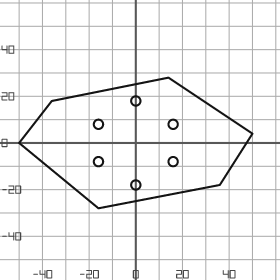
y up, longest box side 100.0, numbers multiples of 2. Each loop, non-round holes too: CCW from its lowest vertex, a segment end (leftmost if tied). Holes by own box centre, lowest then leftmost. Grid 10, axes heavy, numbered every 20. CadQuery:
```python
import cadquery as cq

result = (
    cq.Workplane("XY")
    .moveTo(-16.0, -28.0)
    .lineTo(36.0, -18.0)
    .lineTo(50.0, 4.0)
    .lineTo(14.0, 28.0)
    .lineTo(-36.0, 18.0)
    .lineTo(-50.0, 0.0)
    .close()
    .moveTo(0.0, -18.0)
    .circle(2.0)
    .moveTo(-16.0, -8.0)
    .circle(2.0)
    .moveTo(16.0, -8.0)
    .circle(2.0)
    .moveTo(-16.0, 8.0)
    .circle(2.0)
    .moveTo(16.0, 8.0)
    .circle(2.0)
    .moveTo(0.0, 18.0)
    .circle(2.0)
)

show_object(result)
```